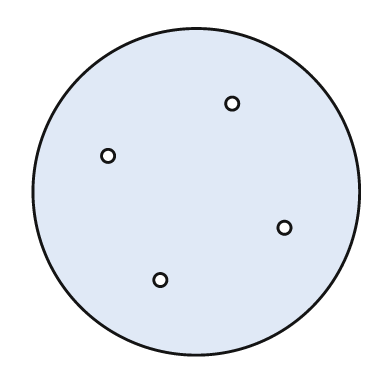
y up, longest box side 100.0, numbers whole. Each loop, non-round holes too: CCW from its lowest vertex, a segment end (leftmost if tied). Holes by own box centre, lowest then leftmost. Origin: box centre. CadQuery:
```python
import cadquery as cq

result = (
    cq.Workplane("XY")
    .moveTo(0.0, 0.0)
    .circle(50.0)
    .moveTo(-11.0, -27.0)
    .circle(2.0)
    .moveTo(27.0, -11.0)
    .circle(2.0)
    .moveTo(-27.0, 11.0)
    .circle(2.0)
    .moveTo(11.0, 27.0)
    .circle(2.0)
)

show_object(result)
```